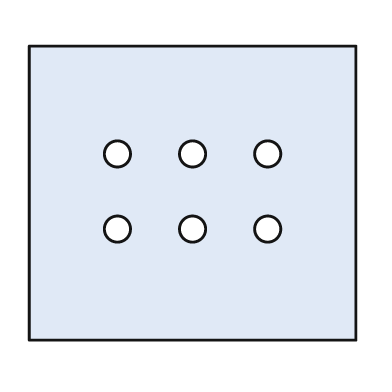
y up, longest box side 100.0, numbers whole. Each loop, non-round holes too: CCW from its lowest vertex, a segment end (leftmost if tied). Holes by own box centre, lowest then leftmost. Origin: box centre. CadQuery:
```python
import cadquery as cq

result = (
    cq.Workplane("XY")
    .moveTo(-50.0, -45.0)
    .lineTo(50.0, -45.0)
    .lineTo(50.0, 45.0)
    .lineTo(-50.0, 45.0)
    .close()
    .moveTo(-23.0, -11.0)
    .circle(4.0)
    .moveTo(0.0, -11.0)
    .circle(4.0)
    .moveTo(23.0, -11.0)
    .circle(4.0)
    .moveTo(-23.0, 12.0)
    .circle(4.0)
    .moveTo(0.0, 12.0)
    .circle(4.0)
    .moveTo(23.0, 12.0)
    .circle(4.0)
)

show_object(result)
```